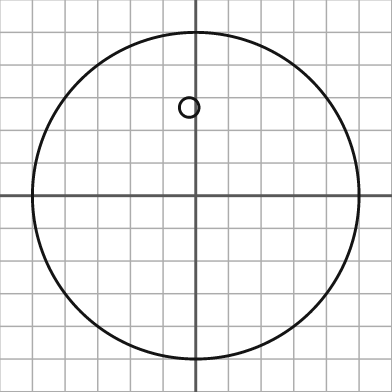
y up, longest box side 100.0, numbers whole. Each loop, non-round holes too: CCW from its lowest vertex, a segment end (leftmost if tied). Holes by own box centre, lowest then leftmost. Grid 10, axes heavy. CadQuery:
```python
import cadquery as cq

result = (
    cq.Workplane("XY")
    .moveTo(0.0, 0.0)
    .circle(50.0)
    .moveTo(-2.0, 27.0)
    .circle(3.0)
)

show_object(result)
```